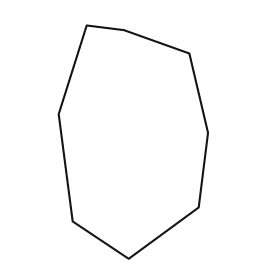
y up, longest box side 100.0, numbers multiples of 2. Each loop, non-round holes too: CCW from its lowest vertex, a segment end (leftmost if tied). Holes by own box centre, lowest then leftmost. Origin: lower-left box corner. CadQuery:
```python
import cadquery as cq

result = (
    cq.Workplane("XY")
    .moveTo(30.0, 0.0)
    .lineTo(60.0, 22.0)
    .lineTo(64.0, 54.0)
    .lineTo(56.0, 88.0)
    .lineTo(28.0, 98.0)
    .lineTo(12.0, 100.0)
    .lineTo(0.0, 62.0)
    .lineTo(6.0, 16.0)
    .close()
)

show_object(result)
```